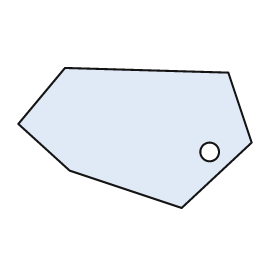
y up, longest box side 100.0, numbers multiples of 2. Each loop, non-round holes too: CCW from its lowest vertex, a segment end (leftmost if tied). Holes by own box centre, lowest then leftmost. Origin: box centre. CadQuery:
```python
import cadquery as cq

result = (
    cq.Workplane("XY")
    .moveTo(20.0, -30.0)
    .lineTo(50.0, -2.0)
    .lineTo(40.0, 28.0)
    .lineTo(-30.0, 30.0)
    .lineTo(-50.0, 6.0)
    .lineTo(-28.0, -14.0)
    .close()
    .moveTo(32.0, -6.0)
    .circle(4.0)
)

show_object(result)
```